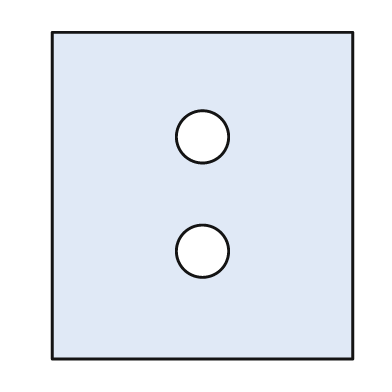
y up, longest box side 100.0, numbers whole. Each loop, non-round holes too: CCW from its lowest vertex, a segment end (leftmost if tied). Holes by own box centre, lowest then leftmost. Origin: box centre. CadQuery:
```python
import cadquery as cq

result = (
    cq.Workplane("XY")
    .moveTo(-46.0, -50.0)
    .lineTo(46.0, -50.0)
    .lineTo(46.0, 50.0)
    .lineTo(-46.0, 50.0)
    .close()
    .moveTo(0.0, -17.0)
    .circle(8.0)
    .moveTo(0.0, 18.0)
    .circle(8.0)
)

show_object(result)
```